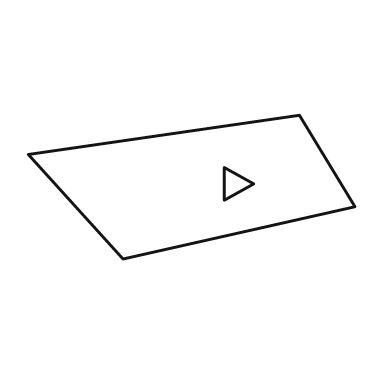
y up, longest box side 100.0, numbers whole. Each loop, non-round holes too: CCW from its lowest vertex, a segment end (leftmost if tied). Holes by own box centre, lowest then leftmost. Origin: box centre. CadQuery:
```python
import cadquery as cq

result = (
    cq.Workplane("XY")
    .moveTo(-21.0, -22.0)
    .lineTo(50.0, -6.0)
    .lineTo(33.0, 22.0)
    .lineTo(-50.0, 10.0)
    .close()
    .moveTo(10.0, -4.0)
    .lineTo(19.0, 1.0)
    .lineTo(10.0, 6.0)
    .close()
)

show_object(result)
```